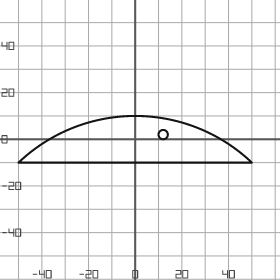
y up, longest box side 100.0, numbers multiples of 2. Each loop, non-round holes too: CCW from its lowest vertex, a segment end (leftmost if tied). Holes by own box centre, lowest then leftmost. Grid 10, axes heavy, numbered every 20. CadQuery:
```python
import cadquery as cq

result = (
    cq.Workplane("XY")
    .moveTo(-50.0, -10.0)
    .lineTo(50.0, -10.0)
    .threePointArc((0.0, 10.0), (-50.0, -10.0))
    .close()
    .moveTo(12.0, 2.0)
    .circle(2.0)
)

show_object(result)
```